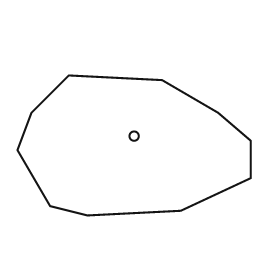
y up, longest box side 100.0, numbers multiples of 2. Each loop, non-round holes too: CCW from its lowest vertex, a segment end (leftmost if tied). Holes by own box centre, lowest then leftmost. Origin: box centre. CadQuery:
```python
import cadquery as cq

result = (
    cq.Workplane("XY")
    .moveTo(-20.0, -30.0)
    .lineTo(20.0, -28.0)
    .lineTo(50.0, -14.0)
    .lineTo(50.0, 2.0)
    .lineTo(36.0, 14.0)
    .lineTo(12.0, 28.0)
    .lineTo(-28.0, 30.0)
    .lineTo(-44.0, 14.0)
    .lineTo(-50.0, -2.0)
    .lineTo(-36.0, -26.0)
    .close()
    .moveTo(0.0, 4.0)
    .circle(2.0)
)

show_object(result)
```